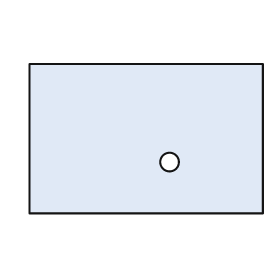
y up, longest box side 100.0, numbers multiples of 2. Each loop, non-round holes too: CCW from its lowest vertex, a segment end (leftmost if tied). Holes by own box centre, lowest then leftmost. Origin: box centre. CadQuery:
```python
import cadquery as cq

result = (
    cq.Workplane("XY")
    .moveTo(-50.0, -32.0)
    .lineTo(50.0, -32.0)
    .lineTo(50.0, 32.0)
    .lineTo(-50.0, 32.0)
    .close()
    .moveTo(10.0, -10.0)
    .circle(4.0)
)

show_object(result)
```